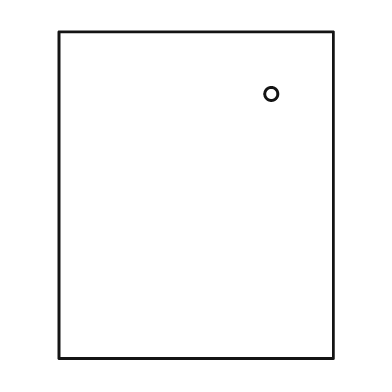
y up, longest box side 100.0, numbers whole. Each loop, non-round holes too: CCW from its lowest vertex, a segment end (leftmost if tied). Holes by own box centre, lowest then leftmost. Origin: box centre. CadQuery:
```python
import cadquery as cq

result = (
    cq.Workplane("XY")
    .moveTo(-42.0, -50.0)
    .lineTo(42.0, -50.0)
    .lineTo(42.0, 50.0)
    .lineTo(-42.0, 50.0)
    .close()
    .moveTo(23.0, 31.0)
    .circle(2.0)
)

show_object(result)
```